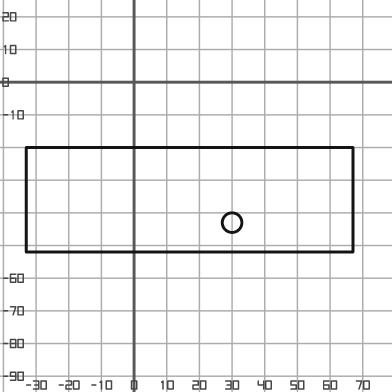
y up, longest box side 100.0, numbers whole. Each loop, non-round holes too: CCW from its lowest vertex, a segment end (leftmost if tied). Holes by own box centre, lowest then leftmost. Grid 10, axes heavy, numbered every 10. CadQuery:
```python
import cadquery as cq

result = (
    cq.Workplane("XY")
    .moveTo(-33.0, -52.0)
    .lineTo(67.0, -52.0)
    .lineTo(67.0, -20.0)
    .lineTo(-33.0, -20.0)
    .close()
    .moveTo(30.0, -43.0)
    .circle(3.0)
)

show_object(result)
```